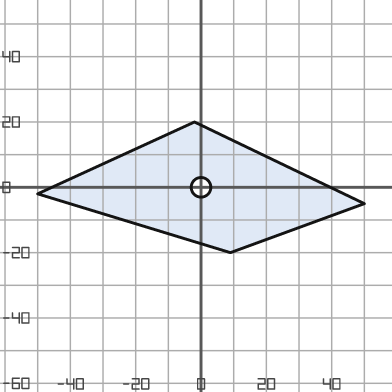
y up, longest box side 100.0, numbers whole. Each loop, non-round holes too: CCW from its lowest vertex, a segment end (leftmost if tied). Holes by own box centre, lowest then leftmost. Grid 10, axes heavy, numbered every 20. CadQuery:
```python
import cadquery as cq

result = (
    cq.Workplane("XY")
    .moveTo(9.0, -20.0)
    .lineTo(50.0, -5.0)
    .lineTo(-2.0, 20.0)
    .lineTo(-50.0, -2.0)
    .close()
    .moveTo(0.0, 0.0)
    .circle(3.0)
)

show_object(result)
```